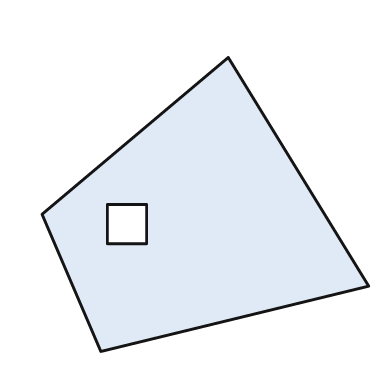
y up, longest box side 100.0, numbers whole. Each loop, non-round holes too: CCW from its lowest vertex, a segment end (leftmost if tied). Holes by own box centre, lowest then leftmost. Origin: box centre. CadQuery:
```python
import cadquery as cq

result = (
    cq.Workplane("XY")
    .moveTo(-32.0, -45.0)
    .lineTo(50.0, -25.0)
    .lineTo(7.0, 45.0)
    .lineTo(-50.0, -3.0)
    .close()
    .moveTo(-30.0, -12.0)
    .lineTo(-18.0, -12.0)
    .lineTo(-18.0, 0.0)
    .lineTo(-30.0, 0.0)
    .close()
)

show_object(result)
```